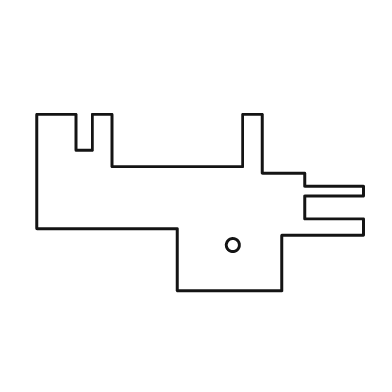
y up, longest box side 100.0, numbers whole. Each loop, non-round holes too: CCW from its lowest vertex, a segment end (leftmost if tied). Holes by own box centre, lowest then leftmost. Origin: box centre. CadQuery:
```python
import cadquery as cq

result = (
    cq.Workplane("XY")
    .moveTo(-7.0, -27.0)
    .lineTo(25.0, -27.0)
    .lineTo(25.0, -10.0)
    .lineTo(50.0, -10.0)
    .lineTo(50.0, -5.0)
    .lineTo(32.0, -5.0)
    .lineTo(32.0, 2.0)
    .lineTo(50.0, 2.0)
    .lineTo(50.0, 5.0)
    .lineTo(32.0, 5.0)
    .lineTo(32.0, 9.0)
    .lineTo(19.0, 9.0)
    .lineTo(19.0, 27.0)
    .lineTo(13.0, 27.0)
    .lineTo(13.0, 11.0)
    .lineTo(-27.0, 11.0)
    .lineTo(-27.0, 27.0)
    .lineTo(-33.0, 27.0)
    .lineTo(-33.0, 16.0)
    .lineTo(-38.0, 16.0)
    .lineTo(-38.0, 27.0)
    .lineTo(-50.0, 27.0)
    .lineTo(-50.0, -8.0)
    .lineTo(-7.0, -8.0)
    .close()
    .moveTo(10.0, -13.0)
    .circle(2.0)
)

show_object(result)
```